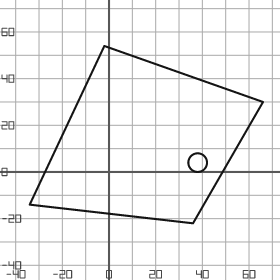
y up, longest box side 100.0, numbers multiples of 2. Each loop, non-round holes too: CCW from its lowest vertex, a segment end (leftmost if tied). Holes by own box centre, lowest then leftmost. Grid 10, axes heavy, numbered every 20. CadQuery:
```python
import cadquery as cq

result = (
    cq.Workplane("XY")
    .moveTo(36.0, -22.0)
    .lineTo(66.0, 30.0)
    .lineTo(-2.0, 54.0)
    .lineTo(-34.0, -14.0)
    .close()
    .moveTo(38.0, 4.0)
    .circle(4.0)
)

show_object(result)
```